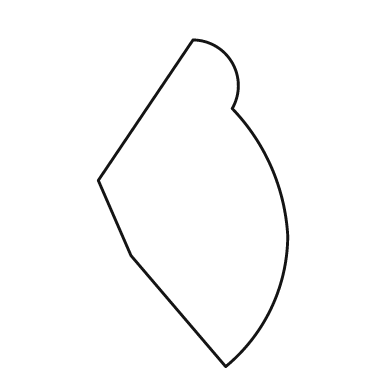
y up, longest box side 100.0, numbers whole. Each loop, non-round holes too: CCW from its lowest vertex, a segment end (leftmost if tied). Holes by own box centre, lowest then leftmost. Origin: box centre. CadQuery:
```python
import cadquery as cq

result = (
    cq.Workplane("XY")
    .moveTo(10.0, -50.0)
    .threePointArc((24.0, -32.0), (29.0, -10.0))
    .threePointArc((24.0, 11.0), (12.0, 29.0))
    .threePointArc((12.0, 43.0), (0.0, 50.0))
    .lineTo(-29.0, 7.0)
    .lineTo(-19.0, -16.0)
    .close()
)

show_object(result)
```